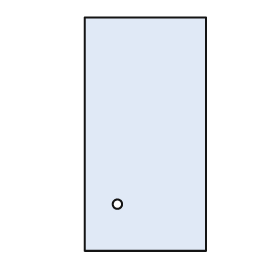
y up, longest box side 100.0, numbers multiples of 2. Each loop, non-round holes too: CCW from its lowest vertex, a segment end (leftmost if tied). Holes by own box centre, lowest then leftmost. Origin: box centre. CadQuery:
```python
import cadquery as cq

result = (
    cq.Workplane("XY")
    .moveTo(-26.0, -50.0)
    .lineTo(26.0, -50.0)
    .lineTo(26.0, 50.0)
    .lineTo(-26.0, 50.0)
    .close()
    .moveTo(-12.0, -30.0)
    .circle(2.0)
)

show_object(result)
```